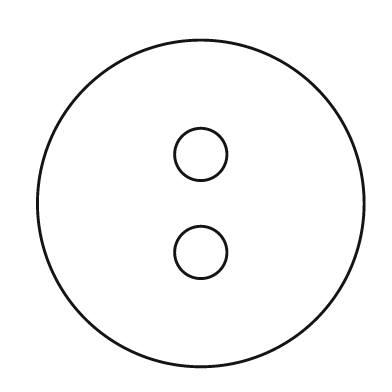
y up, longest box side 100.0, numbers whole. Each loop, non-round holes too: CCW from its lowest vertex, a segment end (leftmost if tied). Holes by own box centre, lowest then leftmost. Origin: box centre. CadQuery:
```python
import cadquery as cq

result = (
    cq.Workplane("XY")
    .moveTo(0.0, 0.0)
    .circle(50.0)
    .moveTo(0.0, -15.0)
    .circle(8.0)
    .moveTo(0.0, 15.0)
    .circle(8.0)
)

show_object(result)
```